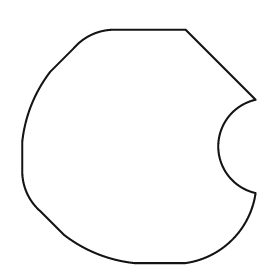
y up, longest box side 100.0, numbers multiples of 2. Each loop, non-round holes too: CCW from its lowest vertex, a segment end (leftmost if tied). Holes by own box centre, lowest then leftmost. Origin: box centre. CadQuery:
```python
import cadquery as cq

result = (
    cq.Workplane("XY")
    .moveTo(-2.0, -50.0)
    .lineTo(20.0, -50.0)
    .threePointArc((40.0, -40.0), (50.0, -20.0))
    .threePointArc((34.0, 0.0), (50.0, 20.0))
    .lineTo(20.0, 50.0)
    .lineTo(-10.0, 50.0)
    .threePointArc((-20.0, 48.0), (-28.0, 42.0))
    .lineTo(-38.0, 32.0)
    .threePointArc((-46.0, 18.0), (-50.0, 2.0))
    .lineTo(-50.0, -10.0)
    .threePointArc((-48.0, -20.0), (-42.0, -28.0))
    .lineTo(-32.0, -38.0)
    .threePointArc((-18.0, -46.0), (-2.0, -50.0))
    .close()
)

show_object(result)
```